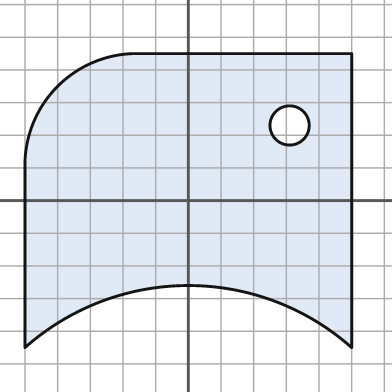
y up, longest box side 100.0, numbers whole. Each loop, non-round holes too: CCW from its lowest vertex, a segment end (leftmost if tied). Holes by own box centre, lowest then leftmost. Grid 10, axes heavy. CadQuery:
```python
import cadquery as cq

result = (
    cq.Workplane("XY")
    .moveTo(-50.0, -45.0)
    .threePointArc((0.0, -26.0), (50.0, -45.0))
    .lineTo(50.0, 45.0)
    .lineTo(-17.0, 45.0)
    .threePointArc((-40.0, 35.0), (-50.0, 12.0))
    .close()
    .moveTo(31.0, 23.0)
    .circle(6.0)
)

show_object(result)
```